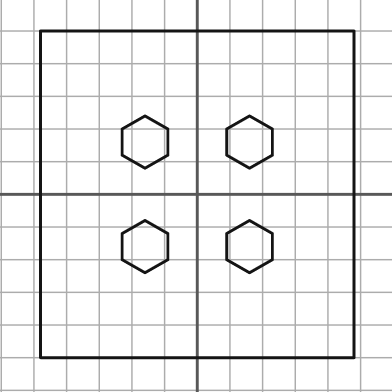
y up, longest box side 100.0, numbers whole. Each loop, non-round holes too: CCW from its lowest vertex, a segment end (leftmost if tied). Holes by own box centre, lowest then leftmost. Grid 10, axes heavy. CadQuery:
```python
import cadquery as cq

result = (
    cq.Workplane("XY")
    .moveTo(-48.0, -50.0)
    .lineTo(48.0, -50.0)
    .lineTo(48.0, 50.0)
    .lineTo(-48.0, 50.0)
    .close()
    .moveTo(-16.0, -24.0)
    .lineTo(-9.0, -20.0)
    .lineTo(-9.0, -12.0)
    .lineTo(-16.0, -8.0)
    .lineTo(-23.0, -12.0)
    .lineTo(-23.0, -20.0)
    .close()
    .moveTo(16.0, -24.0)
    .lineTo(23.0, -20.0)
    .lineTo(23.0, -12.0)
    .lineTo(16.0, -8.0)
    .lineTo(9.0, -12.0)
    .lineTo(9.0, -20.0)
    .close()
    .moveTo(-16.0, 8.0)
    .lineTo(-9.0, 12.0)
    .lineTo(-9.0, 20.0)
    .lineTo(-16.0, 24.0)
    .lineTo(-23.0, 20.0)
    .lineTo(-23.0, 12.0)
    .close()
    .moveTo(16.0, 8.0)
    .lineTo(23.0, 12.0)
    .lineTo(23.0, 20.0)
    .lineTo(16.0, 24.0)
    .lineTo(9.0, 20.0)
    .lineTo(9.0, 12.0)
    .close()
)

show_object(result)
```